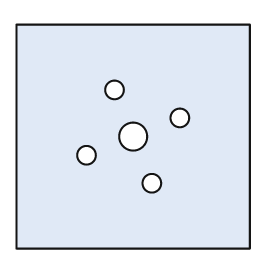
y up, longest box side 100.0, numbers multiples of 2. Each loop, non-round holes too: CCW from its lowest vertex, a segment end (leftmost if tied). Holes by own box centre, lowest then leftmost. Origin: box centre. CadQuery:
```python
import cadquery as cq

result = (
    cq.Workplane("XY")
    .moveTo(-50.0, -48.0)
    .lineTo(50.0, -48.0)
    .lineTo(50.0, 48.0)
    .lineTo(-50.0, 48.0)
    .close()
    .moveTo(8.0, -20.0)
    .circle(4.0)
    .moveTo(-20.0, -8.0)
    .circle(4.0)
    .moveTo(0.0, 0.0)
    .circle(6.0)
    .moveTo(20.0, 8.0)
    .circle(4.0)
    .moveTo(-8.0, 20.0)
    .circle(4.0)
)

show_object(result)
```